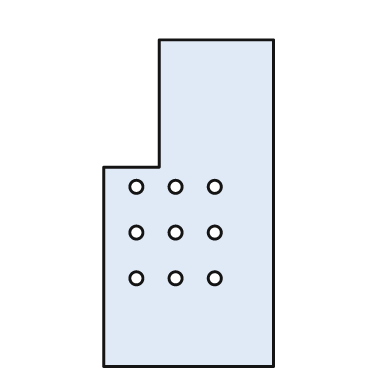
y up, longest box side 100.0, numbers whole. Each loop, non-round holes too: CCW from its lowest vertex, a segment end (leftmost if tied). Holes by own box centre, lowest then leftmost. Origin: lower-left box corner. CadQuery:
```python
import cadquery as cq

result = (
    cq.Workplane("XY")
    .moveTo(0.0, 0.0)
    .lineTo(52.0, 0.0)
    .lineTo(52.0, 100.0)
    .lineTo(17.0, 100.0)
    .lineTo(17.0, 61.0)
    .lineTo(0.0, 61.0)
    .close()
    .moveTo(10.0, 27.0)
    .circle(2.0)
    .moveTo(22.0, 27.0)
    .circle(2.0)
    .moveTo(34.0, 27.0)
    .circle(2.0)
    .moveTo(10.0, 41.0)
    .circle(2.0)
    .moveTo(22.0, 41.0)
    .circle(2.0)
    .moveTo(34.0, 41.0)
    .circle(2.0)
    .moveTo(10.0, 55.0)
    .circle(2.0)
    .moveTo(22.0, 55.0)
    .circle(2.0)
    .moveTo(34.0, 55.0)
    .circle(2.0)
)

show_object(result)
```